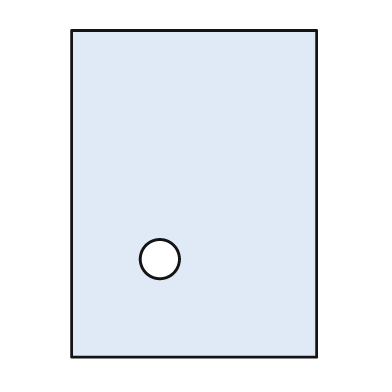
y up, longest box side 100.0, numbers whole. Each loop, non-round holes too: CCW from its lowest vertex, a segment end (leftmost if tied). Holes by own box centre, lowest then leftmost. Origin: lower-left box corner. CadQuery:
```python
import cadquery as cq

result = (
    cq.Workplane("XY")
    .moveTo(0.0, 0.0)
    .lineTo(75.0, 0.0)
    .lineTo(75.0, 100.0)
    .lineTo(0.0, 100.0)
    .close()
    .moveTo(27.0, 30.0)
    .circle(6.0)
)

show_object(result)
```